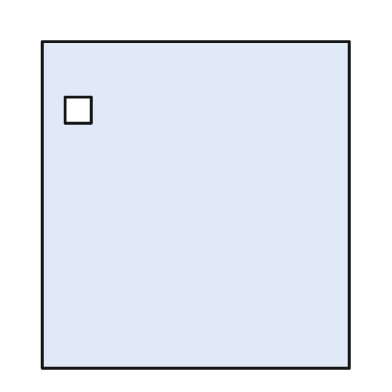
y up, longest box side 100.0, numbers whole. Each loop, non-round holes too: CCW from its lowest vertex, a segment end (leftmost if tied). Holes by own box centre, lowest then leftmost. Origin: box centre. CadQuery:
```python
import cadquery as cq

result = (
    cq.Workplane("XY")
    .moveTo(-47.0, -50.0)
    .lineTo(47.0, -50.0)
    .lineTo(47.0, 50.0)
    .lineTo(-47.0, 50.0)
    .close()
    .moveTo(-40.0, 25.0)
    .lineTo(-32.0, 25.0)
    .lineTo(-32.0, 33.0)
    .lineTo(-40.0, 33.0)
    .close()
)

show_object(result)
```